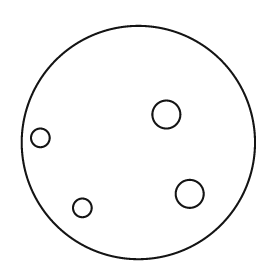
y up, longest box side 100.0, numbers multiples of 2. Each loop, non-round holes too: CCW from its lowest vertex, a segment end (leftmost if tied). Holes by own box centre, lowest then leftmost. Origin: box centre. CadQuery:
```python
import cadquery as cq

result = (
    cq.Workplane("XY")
    .moveTo(0.0, 0.0)
    .circle(50.0)
    .moveTo(-24.0, -28.0)
    .circle(4.0)
    .moveTo(22.0, -22.0)
    .circle(6.0)
    .moveTo(-42.0, 2.0)
    .circle(4.0)
    .moveTo(12.0, 12.0)
    .circle(6.0)
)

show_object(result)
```